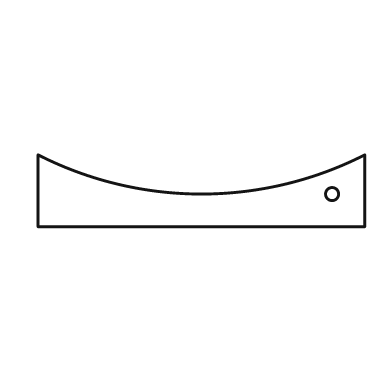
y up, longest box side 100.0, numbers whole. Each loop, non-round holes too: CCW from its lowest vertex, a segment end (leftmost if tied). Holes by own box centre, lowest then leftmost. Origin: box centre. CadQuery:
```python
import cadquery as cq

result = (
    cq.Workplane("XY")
    .moveTo(-50.0, -11.0)
    .lineTo(50.0, -11.0)
    .lineTo(50.0, 11.0)
    .threePointArc((0.0, -1.0), (-50.0, 11.0))
    .close()
    .moveTo(40.0, -1.0)
    .circle(2.0)
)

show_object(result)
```